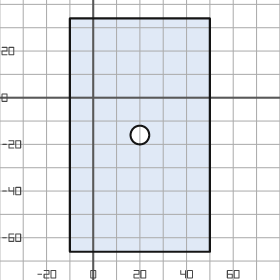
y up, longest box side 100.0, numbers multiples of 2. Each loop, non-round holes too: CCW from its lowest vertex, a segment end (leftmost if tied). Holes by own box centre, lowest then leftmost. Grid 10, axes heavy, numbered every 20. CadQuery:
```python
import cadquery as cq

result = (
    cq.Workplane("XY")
    .moveTo(-10.0, -66.0)
    .lineTo(50.0, -66.0)
    .lineTo(50.0, 34.0)
    .lineTo(-10.0, 34.0)
    .close()
    .moveTo(20.0, -16.0)
    .circle(4.0)
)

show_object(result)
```